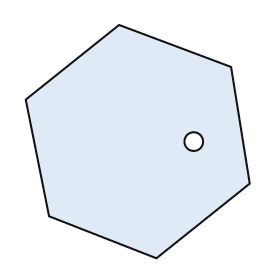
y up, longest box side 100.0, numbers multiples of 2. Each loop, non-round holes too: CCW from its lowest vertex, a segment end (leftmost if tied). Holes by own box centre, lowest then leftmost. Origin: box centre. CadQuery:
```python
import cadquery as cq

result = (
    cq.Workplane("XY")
    .moveTo(8.0, -50.0)
    .lineTo(48.0, -18.0)
    .lineTo(40.0, 32.0)
    .lineTo(-8.0, 50.0)
    .lineTo(-48.0, 18.0)
    .lineTo(-38.0, -32.0)
    .close()
    .moveTo(24.0, 0.0)
    .circle(4.0)
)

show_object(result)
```